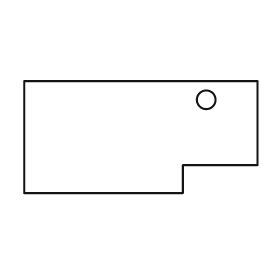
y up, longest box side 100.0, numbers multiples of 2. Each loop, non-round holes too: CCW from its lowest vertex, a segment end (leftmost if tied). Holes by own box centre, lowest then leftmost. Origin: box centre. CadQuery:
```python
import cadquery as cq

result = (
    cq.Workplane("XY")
    .moveTo(-50.0, -24.0)
    .lineTo(18.0, -24.0)
    .lineTo(18.0, -12.0)
    .lineTo(50.0, -12.0)
    .lineTo(50.0, 24.0)
    .lineTo(-50.0, 24.0)
    .close()
    .moveTo(28.0, 16.0)
    .circle(4.0)
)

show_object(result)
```